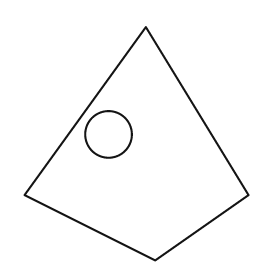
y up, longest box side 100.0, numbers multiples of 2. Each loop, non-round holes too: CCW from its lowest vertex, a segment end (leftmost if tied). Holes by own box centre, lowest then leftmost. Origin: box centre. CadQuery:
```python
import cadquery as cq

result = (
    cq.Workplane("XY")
    .moveTo(8.0, -50.0)
    .lineTo(48.0, -22.0)
    .lineTo(4.0, 50.0)
    .lineTo(-48.0, -22.0)
    .close()
    .moveTo(-12.0, 4.0)
    .circle(10.0)
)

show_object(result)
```